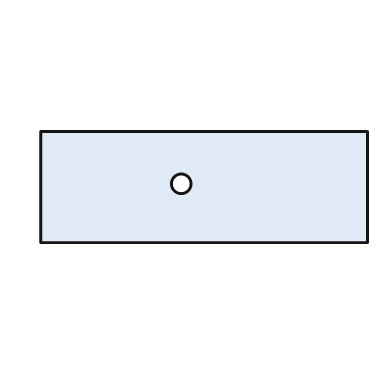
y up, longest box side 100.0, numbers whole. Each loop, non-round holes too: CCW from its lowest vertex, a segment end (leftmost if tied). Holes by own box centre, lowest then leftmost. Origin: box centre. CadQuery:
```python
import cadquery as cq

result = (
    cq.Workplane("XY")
    .moveTo(-50.0, -17.0)
    .lineTo(50.0, -17.0)
    .lineTo(50.0, 17.0)
    .lineTo(-50.0, 17.0)
    .close()
    .moveTo(-7.0, 1.0)
    .circle(3.0)
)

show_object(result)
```